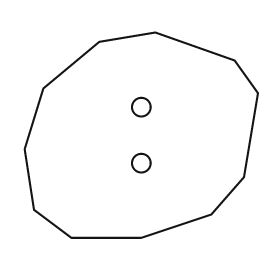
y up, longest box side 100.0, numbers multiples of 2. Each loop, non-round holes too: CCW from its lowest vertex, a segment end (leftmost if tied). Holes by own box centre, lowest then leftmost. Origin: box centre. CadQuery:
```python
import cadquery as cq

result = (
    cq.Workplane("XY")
    .moveTo(-30.0, -44.0)
    .lineTo(0.0, -44.0)
    .lineTo(30.0, -34.0)
    .lineTo(44.0, -18.0)
    .lineTo(50.0, 18.0)
    .lineTo(40.0, 32.0)
    .lineTo(6.0, 44.0)
    .lineTo(-18.0, 40.0)
    .lineTo(-42.0, 20.0)
    .lineTo(-50.0, -6.0)
    .lineTo(-46.0, -32.0)
    .close()
    .moveTo(0.0, -12.0)
    .circle(4.0)
    .moveTo(0.0, 12.0)
    .circle(4.0)
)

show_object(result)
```